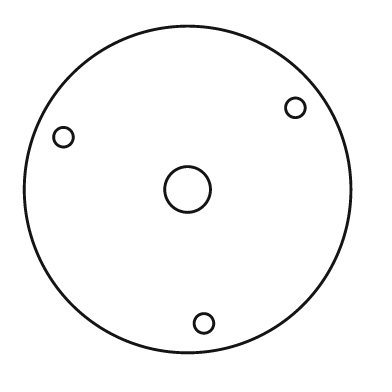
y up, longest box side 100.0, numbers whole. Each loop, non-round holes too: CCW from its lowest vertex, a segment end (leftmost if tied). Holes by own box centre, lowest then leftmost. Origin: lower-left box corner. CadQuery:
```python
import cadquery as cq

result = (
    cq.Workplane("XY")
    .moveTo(50.0, 50.0)
    .circle(50.0)
    .moveTo(55.0, 9.0)
    .circle(3.0)
    .moveTo(50.0, 50.0)
    .circle(7.0)
    .moveTo(12.0, 66.0)
    .circle(3.0)
    .moveTo(83.0, 75.0)
    .circle(3.0)
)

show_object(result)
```